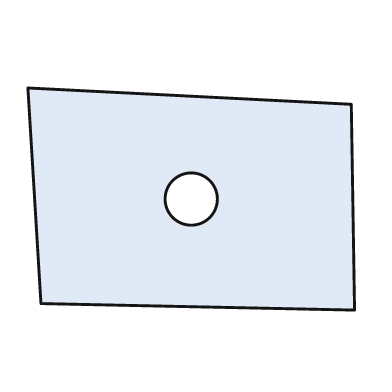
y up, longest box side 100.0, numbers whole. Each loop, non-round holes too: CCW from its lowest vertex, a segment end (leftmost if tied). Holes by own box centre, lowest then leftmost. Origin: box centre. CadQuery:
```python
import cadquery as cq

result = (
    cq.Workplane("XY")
    .moveTo(50.0, -34.0)
    .lineTo(49.0, 29.0)
    .lineTo(-50.0, 34.0)
    .lineTo(-46.0, -32.0)
    .close()
    .moveTo(0.0, 0.0)
    .circle(8.0)
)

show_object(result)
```